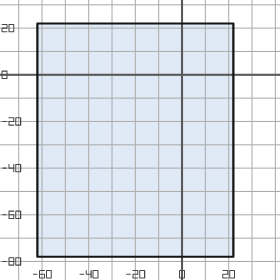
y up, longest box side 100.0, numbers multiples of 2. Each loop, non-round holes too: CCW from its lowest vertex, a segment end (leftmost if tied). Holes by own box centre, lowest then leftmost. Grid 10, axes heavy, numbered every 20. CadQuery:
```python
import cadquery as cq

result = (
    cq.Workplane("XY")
    .moveTo(-62.0, -78.0)
    .lineTo(22.0, -78.0)
    .lineTo(22.0, 22.0)
    .lineTo(-62.0, 22.0)
    .close()
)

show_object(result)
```